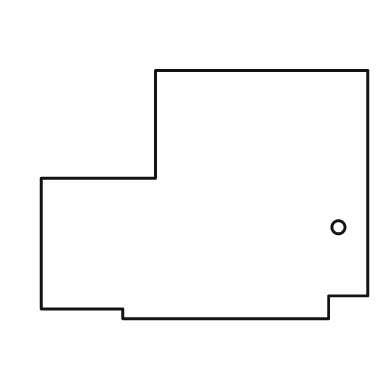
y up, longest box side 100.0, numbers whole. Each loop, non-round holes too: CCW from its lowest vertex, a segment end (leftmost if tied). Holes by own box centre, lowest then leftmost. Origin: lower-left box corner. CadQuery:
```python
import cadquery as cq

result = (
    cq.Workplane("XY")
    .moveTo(25.0, 0.0)
    .lineTo(88.0, 0.0)
    .lineTo(88.0, 7.0)
    .lineTo(100.0, 7.0)
    .lineTo(100.0, 76.0)
    .lineTo(35.0, 76.0)
    .lineTo(35.0, 43.0)
    .lineTo(0.0, 43.0)
    .lineTo(0.0, 3.0)
    .lineTo(25.0, 3.0)
    .close()
    .moveTo(91.0, 28.0)
    .circle(2.0)
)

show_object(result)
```